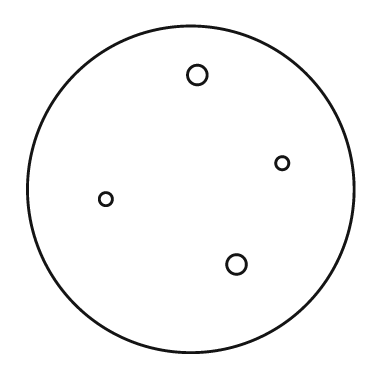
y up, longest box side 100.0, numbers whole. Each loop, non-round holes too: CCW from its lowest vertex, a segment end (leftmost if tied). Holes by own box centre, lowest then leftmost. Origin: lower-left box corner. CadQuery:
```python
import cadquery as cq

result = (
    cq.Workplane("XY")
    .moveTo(50.0, 50.0)
    .circle(50.0)
    .moveTo(64.0, 27.0)
    .circle(3.0)
    .moveTo(24.0, 47.0)
    .circle(2.0)
    .moveTo(78.0, 58.0)
    .circle(2.0)
    .moveTo(52.0, 85.0)
    .circle(3.0)
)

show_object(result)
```